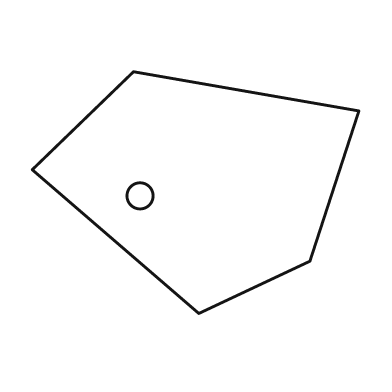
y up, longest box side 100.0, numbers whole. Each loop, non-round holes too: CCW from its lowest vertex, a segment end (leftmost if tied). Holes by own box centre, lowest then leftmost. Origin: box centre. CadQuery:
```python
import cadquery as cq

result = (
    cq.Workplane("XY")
    .moveTo(1.0, -37.0)
    .lineTo(35.0, -21.0)
    .lineTo(50.0, 25.0)
    .lineTo(-19.0, 37.0)
    .lineTo(-50.0, 7.0)
    .close()
    .moveTo(-17.0, -1.0)
    .circle(4.0)
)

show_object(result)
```